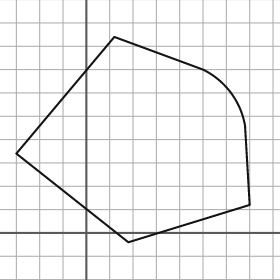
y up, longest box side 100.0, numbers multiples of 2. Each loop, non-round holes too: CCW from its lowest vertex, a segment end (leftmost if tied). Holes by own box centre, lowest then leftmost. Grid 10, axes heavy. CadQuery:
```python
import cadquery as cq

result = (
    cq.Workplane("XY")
    .moveTo(18.0, -4.0)
    .lineTo(70.0, 12.0)
    .lineTo(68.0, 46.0)
    .threePointArc((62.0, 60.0), (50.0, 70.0))
    .lineTo(12.0, 84.0)
    .lineTo(-30.0, 34.0)
    .close()
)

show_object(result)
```